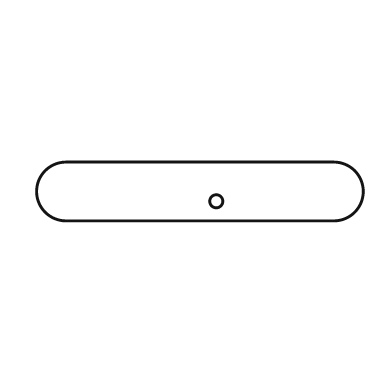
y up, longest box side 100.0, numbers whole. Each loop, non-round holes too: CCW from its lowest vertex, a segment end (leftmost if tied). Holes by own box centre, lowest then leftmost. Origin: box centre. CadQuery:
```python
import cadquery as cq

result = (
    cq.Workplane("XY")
    .moveTo(-41.0, -9.0)
    .lineTo(41.0, -9.0)
    .threePointArc((50.0, 0.0), (41.0, 9.0))
    .lineTo(-41.0, 9.0)
    .threePointArc((-50.0, 0.0), (-41.0, -9.0))
    .close()
    .moveTo(5.0, -3.0)
    .circle(2.0)
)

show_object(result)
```